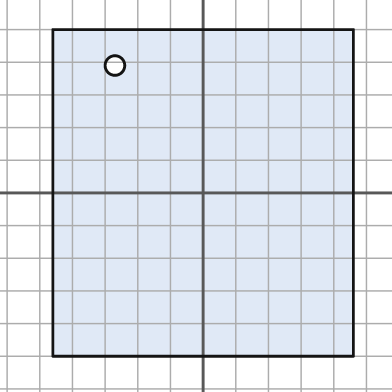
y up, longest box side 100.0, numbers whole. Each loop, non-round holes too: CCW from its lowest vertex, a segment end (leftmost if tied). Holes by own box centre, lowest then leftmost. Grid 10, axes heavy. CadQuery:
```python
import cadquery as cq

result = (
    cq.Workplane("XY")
    .moveTo(-46.0, -50.0)
    .lineTo(46.0, -50.0)
    .lineTo(46.0, 50.0)
    .lineTo(-46.0, 50.0)
    .close()
    .moveTo(-27.0, 39.0)
    .circle(3.0)
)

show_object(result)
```